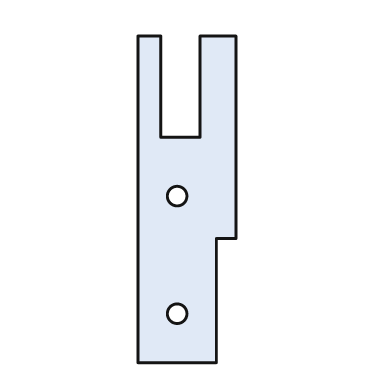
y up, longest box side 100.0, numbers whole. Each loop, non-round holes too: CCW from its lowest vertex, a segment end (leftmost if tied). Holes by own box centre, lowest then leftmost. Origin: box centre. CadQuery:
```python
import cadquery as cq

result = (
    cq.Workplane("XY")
    .moveTo(-15.0, -50.0)
    .lineTo(9.0, -50.0)
    .lineTo(9.0, -12.0)
    .lineTo(15.0, -12.0)
    .lineTo(15.0, 50.0)
    .lineTo(4.0, 50.0)
    .lineTo(4.0, 19.0)
    .lineTo(-8.0, 19.0)
    .lineTo(-8.0, 50.0)
    .lineTo(-15.0, 50.0)
    .close()
    .moveTo(-3.0, -35.0)
    .circle(3.0)
    .moveTo(-3.0, 1.0)
    .circle(3.0)
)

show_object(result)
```